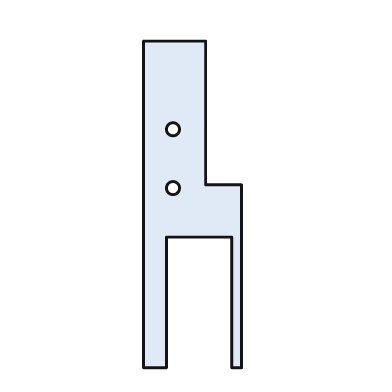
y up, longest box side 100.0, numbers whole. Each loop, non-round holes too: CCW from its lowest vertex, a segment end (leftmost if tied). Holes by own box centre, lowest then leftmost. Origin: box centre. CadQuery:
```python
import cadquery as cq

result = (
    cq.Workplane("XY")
    .moveTo(-15.0, -50.0)
    .lineTo(-8.0, -50.0)
    .lineTo(-8.0, -10.0)
    .lineTo(12.0, -10.0)
    .lineTo(12.0, -50.0)
    .lineTo(15.0, -50.0)
    .lineTo(15.0, 6.0)
    .lineTo(4.0, 6.0)
    .lineTo(4.0, 50.0)
    .lineTo(-15.0, 50.0)
    .close()
    .moveTo(-6.0, 5.0)
    .circle(2.0)
    .moveTo(-6.0, 23.0)
    .circle(2.0)
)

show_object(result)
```